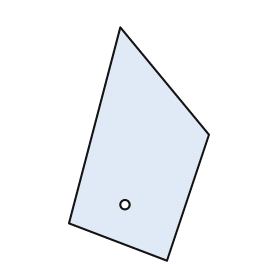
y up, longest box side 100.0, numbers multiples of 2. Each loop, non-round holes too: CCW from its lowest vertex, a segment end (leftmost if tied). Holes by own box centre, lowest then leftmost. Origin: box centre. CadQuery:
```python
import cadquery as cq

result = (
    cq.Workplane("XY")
    .moveTo(12.0, -50.0)
    .lineTo(30.0, 4.0)
    .lineTo(-8.0, 50.0)
    .lineTo(-30.0, -34.0)
    .close()
    .moveTo(-6.0, -26.0)
    .circle(2.0)
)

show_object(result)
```